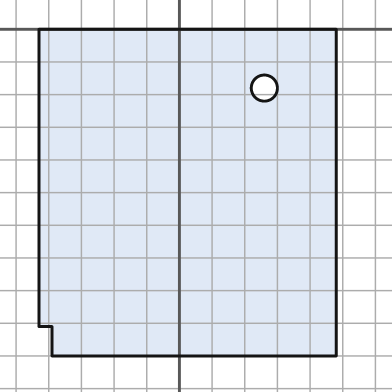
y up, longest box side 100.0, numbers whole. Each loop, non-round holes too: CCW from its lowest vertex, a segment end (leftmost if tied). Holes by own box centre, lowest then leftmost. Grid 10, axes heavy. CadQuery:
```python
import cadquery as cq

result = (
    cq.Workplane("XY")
    .moveTo(-39.0, -100.0)
    .lineTo(48.0, -100.0)
    .lineTo(48.0, 0.0)
    .lineTo(-43.0, 0.0)
    .lineTo(-43.0, -91.0)
    .lineTo(-39.0, -91.0)
    .close()
    .moveTo(26.0, -18.0)
    .circle(4.0)
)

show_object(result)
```